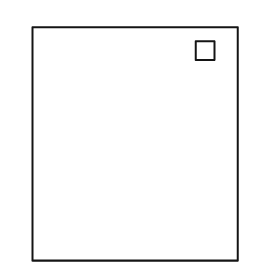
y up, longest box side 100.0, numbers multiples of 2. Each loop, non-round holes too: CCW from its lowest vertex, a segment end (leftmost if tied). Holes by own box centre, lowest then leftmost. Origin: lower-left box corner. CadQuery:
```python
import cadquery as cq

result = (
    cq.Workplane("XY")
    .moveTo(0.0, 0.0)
    .lineTo(88.0, 0.0)
    .lineTo(88.0, 100.0)
    .lineTo(0.0, 100.0)
    .close()
    .moveTo(70.0, 86.0)
    .lineTo(78.0, 86.0)
    .lineTo(78.0, 94.0)
    .lineTo(70.0, 94.0)
    .close()
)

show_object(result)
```